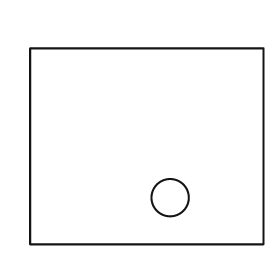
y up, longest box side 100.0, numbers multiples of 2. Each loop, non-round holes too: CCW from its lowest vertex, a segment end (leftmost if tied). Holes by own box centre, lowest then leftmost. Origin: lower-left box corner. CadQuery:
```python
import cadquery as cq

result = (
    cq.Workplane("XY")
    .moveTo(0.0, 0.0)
    .lineTo(100.0, 0.0)
    .lineTo(100.0, 84.0)
    .lineTo(0.0, 84.0)
    .close()
    .moveTo(60.0, 20.0)
    .circle(8.0)
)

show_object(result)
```